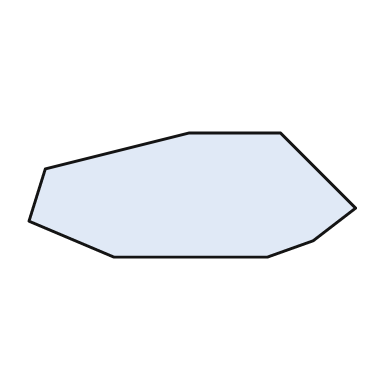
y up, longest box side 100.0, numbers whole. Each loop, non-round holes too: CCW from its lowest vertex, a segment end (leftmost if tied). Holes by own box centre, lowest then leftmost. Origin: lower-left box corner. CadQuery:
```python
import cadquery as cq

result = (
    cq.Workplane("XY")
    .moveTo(26.0, 0.0)
    .lineTo(73.0, 0.0)
    .lineTo(87.0, 5.0)
    .lineTo(100.0, 15.0)
    .lineTo(77.0, 38.0)
    .lineTo(49.0, 38.0)
    .lineTo(5.0, 27.0)
    .lineTo(0.0, 11.0)
    .close()
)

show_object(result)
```